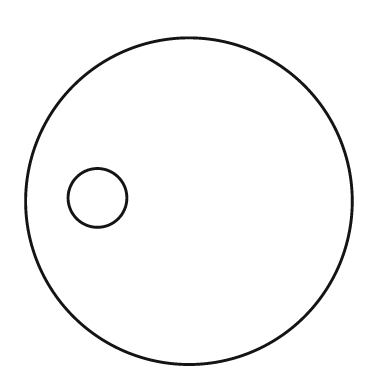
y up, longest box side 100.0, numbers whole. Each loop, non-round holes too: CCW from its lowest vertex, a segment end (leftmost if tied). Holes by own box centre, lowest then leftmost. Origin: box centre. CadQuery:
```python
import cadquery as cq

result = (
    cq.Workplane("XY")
    .moveTo(0.0, 0.0)
    .circle(50.0)
    .moveTo(-28.0, 1.0)
    .circle(9.0)
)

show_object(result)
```